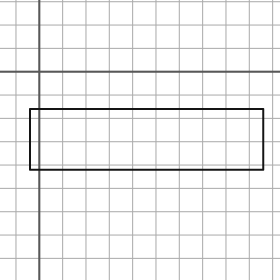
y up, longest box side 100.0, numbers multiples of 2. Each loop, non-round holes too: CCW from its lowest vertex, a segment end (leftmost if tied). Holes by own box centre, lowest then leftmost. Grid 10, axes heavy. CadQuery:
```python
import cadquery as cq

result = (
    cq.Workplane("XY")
    .moveTo(-4.0, -42.0)
    .lineTo(96.0, -42.0)
    .lineTo(96.0, -16.0)
    .lineTo(-4.0, -16.0)
    .close()
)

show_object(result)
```